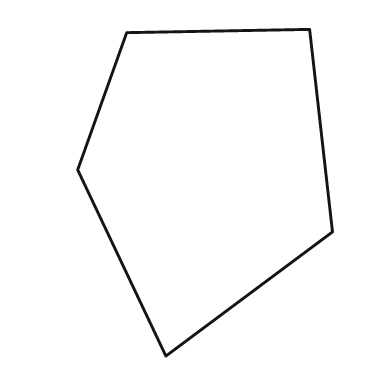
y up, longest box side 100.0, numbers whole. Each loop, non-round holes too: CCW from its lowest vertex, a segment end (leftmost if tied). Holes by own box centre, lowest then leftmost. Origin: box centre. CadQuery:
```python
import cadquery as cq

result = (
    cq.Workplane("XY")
    .moveTo(-12.0, -50.0)
    .lineTo(39.0, -12.0)
    .lineTo(32.0, 50.0)
    .lineTo(-24.0, 49.0)
    .lineTo(-39.0, 7.0)
    .close()
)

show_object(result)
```